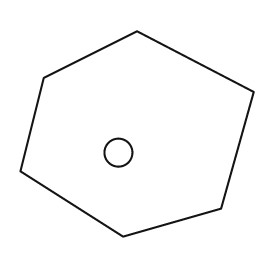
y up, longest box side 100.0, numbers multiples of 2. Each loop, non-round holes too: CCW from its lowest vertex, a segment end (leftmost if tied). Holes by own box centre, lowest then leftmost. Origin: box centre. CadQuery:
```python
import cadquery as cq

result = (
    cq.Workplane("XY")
    .moveTo(-6.0, -44.0)
    .lineTo(36.0, -32.0)
    .lineTo(50.0, 18.0)
    .lineTo(0.0, 44.0)
    .lineTo(-40.0, 24.0)
    .lineTo(-50.0, -16.0)
    .close()
    .moveTo(-8.0, -8.0)
    .circle(6.0)
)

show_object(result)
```